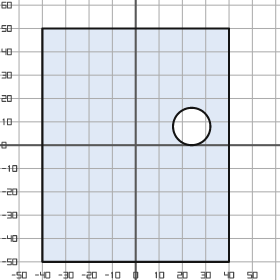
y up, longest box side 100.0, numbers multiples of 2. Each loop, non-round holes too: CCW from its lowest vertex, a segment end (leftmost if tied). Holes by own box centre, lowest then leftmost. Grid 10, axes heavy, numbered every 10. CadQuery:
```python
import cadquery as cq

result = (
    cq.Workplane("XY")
    .moveTo(-40.0, -50.0)
    .lineTo(40.0, -50.0)
    .lineTo(40.0, 50.0)
    .lineTo(-40.0, 50.0)
    .close()
    .moveTo(24.0, 8.0)
    .circle(8.0)
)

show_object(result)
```